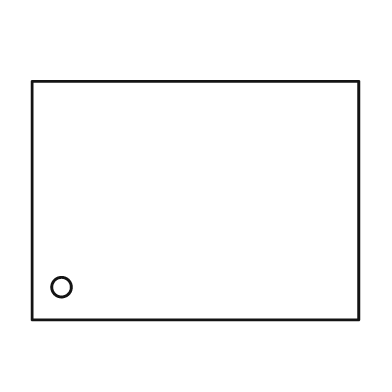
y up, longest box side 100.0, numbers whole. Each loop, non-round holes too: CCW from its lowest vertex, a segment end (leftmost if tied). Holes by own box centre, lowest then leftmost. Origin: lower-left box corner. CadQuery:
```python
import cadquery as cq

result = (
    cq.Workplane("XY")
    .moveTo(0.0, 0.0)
    .lineTo(100.0, 0.0)
    .lineTo(100.0, 73.0)
    .lineTo(0.0, 73.0)
    .close()
    .moveTo(9.0, 10.0)
    .circle(3.0)
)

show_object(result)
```